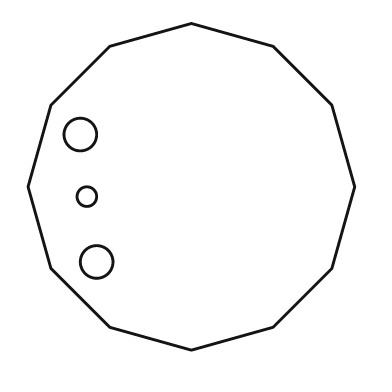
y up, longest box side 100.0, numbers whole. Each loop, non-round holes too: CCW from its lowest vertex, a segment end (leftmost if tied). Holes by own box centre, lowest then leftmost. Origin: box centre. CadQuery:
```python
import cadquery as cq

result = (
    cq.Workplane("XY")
    .moveTo(0.0, -50.0)
    .lineTo(25.0, -43.0)
    .lineTo(43.0, -25.0)
    .lineTo(50.0, 0.0)
    .lineTo(43.0, 25.0)
    .lineTo(25.0, 43.0)
    .lineTo(0.0, 50.0)
    .lineTo(-25.0, 43.0)
    .lineTo(-43.0, 25.0)
    .lineTo(-50.0, 0.0)
    .lineTo(-43.0, -25.0)
    .lineTo(-25.0, -43.0)
    .close()
    .moveTo(-29.0, -23.0)
    .circle(5.0)
    .moveTo(-32.0, -3.0)
    .circle(3.0)
    .moveTo(-34.0, 16.0)
    .circle(5.0)
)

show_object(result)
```